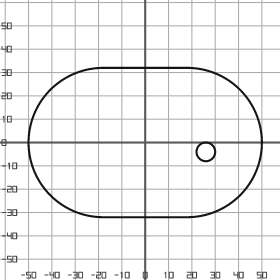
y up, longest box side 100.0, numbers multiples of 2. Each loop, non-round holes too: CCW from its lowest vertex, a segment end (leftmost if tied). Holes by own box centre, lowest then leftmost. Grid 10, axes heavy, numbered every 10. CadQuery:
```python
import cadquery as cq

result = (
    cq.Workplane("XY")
    .moveTo(-18.0, -32.0)
    .lineTo(18.0, -32.0)
    .threePointArc((50.0, 0.0), (18.0, 32.0))
    .lineTo(-18.0, 32.0)
    .threePointArc((-50.0, 0.0), (-18.0, -32.0))
    .close()
    .moveTo(26.0, -4.0)
    .circle(4.0)
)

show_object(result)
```